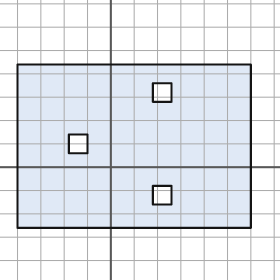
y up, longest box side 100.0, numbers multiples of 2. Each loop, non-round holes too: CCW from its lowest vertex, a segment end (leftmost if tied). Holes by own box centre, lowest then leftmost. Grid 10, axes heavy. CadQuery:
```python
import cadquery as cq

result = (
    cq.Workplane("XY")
    .moveTo(-40.0, -26.0)
    .lineTo(60.0, -26.0)
    .lineTo(60.0, 44.0)
    .lineTo(-40.0, 44.0)
    .close()
    .moveTo(18.0, -16.0)
    .lineTo(26.0, -16.0)
    .lineTo(26.0, -8.0)
    .lineTo(18.0, -8.0)
    .close()
    .moveTo(-18.0, 6.0)
    .lineTo(-10.0, 6.0)
    .lineTo(-10.0, 14.0)
    .lineTo(-18.0, 14.0)
    .close()
    .moveTo(18.0, 28.0)
    .lineTo(26.0, 28.0)
    .lineTo(26.0, 36.0)
    .lineTo(18.0, 36.0)
    .close()
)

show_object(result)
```